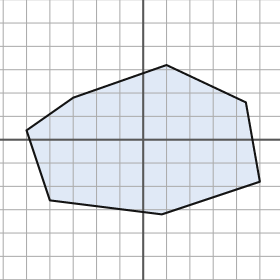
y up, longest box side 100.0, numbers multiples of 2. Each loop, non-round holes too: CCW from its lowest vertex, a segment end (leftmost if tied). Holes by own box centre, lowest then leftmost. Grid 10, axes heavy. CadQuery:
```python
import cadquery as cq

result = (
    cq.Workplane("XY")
    .moveTo(8.0, -32.0)
    .lineTo(50.0, -18.0)
    .lineTo(44.0, 16.0)
    .lineTo(10.0, 32.0)
    .lineTo(-30.0, 18.0)
    .lineTo(-50.0, 4.0)
    .lineTo(-40.0, -26.0)
    .close()
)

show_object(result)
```